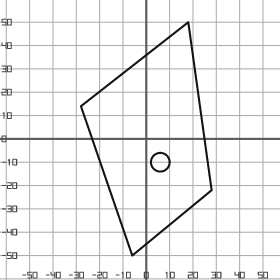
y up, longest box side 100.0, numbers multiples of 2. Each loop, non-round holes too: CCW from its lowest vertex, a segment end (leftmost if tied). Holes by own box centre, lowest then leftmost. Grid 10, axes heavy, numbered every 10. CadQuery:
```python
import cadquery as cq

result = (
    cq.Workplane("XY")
    .moveTo(-6.0, -50.0)
    .lineTo(28.0, -22.0)
    .lineTo(18.0, 50.0)
    .lineTo(-28.0, 14.0)
    .close()
    .moveTo(6.0, -10.0)
    .circle(4.0)
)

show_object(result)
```